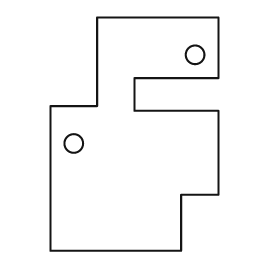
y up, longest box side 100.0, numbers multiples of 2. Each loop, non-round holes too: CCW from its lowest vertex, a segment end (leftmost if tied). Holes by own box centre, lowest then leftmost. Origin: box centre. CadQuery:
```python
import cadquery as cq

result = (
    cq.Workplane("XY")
    .moveTo(-36.0, -50.0)
    .lineTo(20.0, -50.0)
    .lineTo(20.0, -26.0)
    .lineTo(36.0, -26.0)
    .lineTo(36.0, 10.0)
    .lineTo(0.0, 10.0)
    .lineTo(0.0, 24.0)
    .lineTo(36.0, 24.0)
    .lineTo(36.0, 50.0)
    .lineTo(-16.0, 50.0)
    .lineTo(-16.0, 12.0)
    .lineTo(-36.0, 12.0)
    .close()
    .moveTo(-26.0, -4.0)
    .circle(4.0)
    .moveTo(26.0, 34.0)
    .circle(4.0)
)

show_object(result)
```